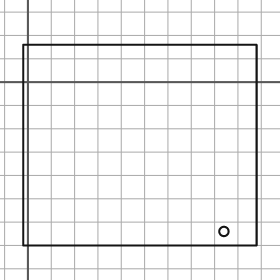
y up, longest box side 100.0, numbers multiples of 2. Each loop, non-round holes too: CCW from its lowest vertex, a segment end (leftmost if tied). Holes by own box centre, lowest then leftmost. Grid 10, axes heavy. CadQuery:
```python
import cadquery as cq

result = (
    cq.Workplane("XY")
    .moveTo(-2.0, -70.0)
    .lineTo(98.0, -70.0)
    .lineTo(98.0, 16.0)
    .lineTo(-2.0, 16.0)
    .close()
    .moveTo(84.0, -64.0)
    .circle(2.0)
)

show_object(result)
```